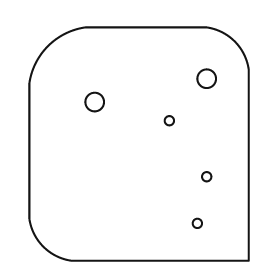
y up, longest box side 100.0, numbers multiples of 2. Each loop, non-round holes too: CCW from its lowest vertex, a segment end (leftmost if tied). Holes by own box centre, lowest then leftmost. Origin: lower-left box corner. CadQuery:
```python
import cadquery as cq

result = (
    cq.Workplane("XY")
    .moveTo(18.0, 0.0)
    .lineTo(94.0, 0.0)
    .lineTo(94.0, 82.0)
    .threePointArc((88.0, 94.0), (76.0, 100.0))
    .lineTo(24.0, 100.0)
    .threePointArc((8.0, 92.0), (0.0, 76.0))
    .lineTo(0.0, 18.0)
    .threePointArc((6.0, 6.0), (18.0, 0.0))
    .close()
    .moveTo(72.0, 16.0)
    .circle(2.0)
    .moveTo(76.0, 36.0)
    .circle(2.0)
    .moveTo(60.0, 60.0)
    .circle(2.0)
    .moveTo(28.0, 68.0)
    .circle(4.0)
    .moveTo(76.0, 78.0)
    .circle(4.0)
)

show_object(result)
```